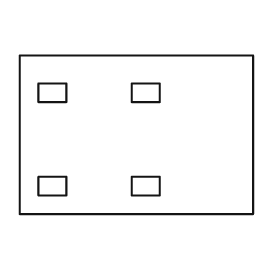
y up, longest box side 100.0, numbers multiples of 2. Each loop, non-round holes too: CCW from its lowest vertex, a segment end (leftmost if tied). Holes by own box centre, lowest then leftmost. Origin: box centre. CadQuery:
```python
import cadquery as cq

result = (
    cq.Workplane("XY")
    .moveTo(-50.0, -34.0)
    .lineTo(50.0, -34.0)
    .lineTo(50.0, 34.0)
    .lineTo(-50.0, 34.0)
    .close()
    .moveTo(-42.0, -26.0)
    .lineTo(-30.0, -26.0)
    .lineTo(-30.0, -18.0)
    .lineTo(-42.0, -18.0)
    .close()
    .moveTo(-2.0, -26.0)
    .lineTo(10.0, -26.0)
    .lineTo(10.0, -18.0)
    .lineTo(-2.0, -18.0)
    .close()
    .moveTo(-42.0, 14.0)
    .lineTo(-30.0, 14.0)
    .lineTo(-30.0, 22.0)
    .lineTo(-42.0, 22.0)
    .close()
    .moveTo(-2.0, 14.0)
    .lineTo(10.0, 14.0)
    .lineTo(10.0, 22.0)
    .lineTo(-2.0, 22.0)
    .close()
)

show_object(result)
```